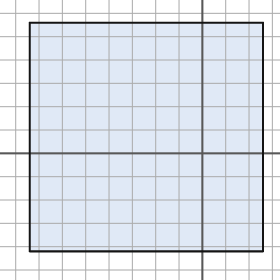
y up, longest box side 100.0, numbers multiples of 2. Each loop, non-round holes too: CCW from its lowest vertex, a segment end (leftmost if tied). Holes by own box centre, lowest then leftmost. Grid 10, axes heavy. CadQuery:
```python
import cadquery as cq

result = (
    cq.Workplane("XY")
    .moveTo(-74.0, -42.0)
    .lineTo(26.0, -42.0)
    .lineTo(26.0, 56.0)
    .lineTo(-74.0, 56.0)
    .close()
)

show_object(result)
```